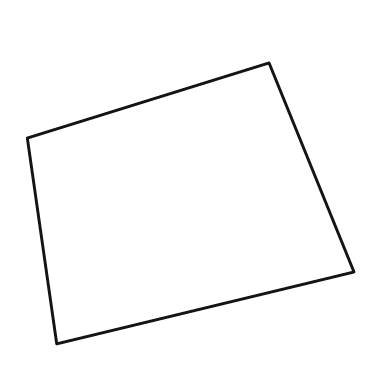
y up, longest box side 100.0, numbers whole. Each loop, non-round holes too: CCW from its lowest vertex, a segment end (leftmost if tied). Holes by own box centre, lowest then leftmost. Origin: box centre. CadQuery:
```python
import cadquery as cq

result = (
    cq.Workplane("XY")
    .moveTo(-41.0, -43.0)
    .lineTo(50.0, -21.0)
    .lineTo(24.0, 43.0)
    .lineTo(-50.0, 20.0)
    .close()
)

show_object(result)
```